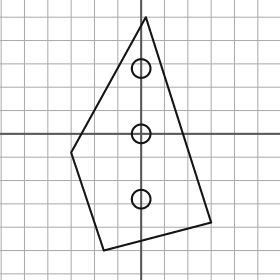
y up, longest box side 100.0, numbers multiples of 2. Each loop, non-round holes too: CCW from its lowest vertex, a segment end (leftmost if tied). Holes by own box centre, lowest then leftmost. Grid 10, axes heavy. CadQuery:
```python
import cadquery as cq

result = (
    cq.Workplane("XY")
    .moveTo(-16.0, -50.0)
    .lineTo(30.0, -38.0)
    .lineTo(2.0, 50.0)
    .lineTo(-30.0, -8.0)
    .close()
    .moveTo(0.0, -28.0)
    .circle(4.0)
    .moveTo(0.0, 0.0)
    .circle(4.0)
    .moveTo(0.0, 28.0)
    .circle(4.0)
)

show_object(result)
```